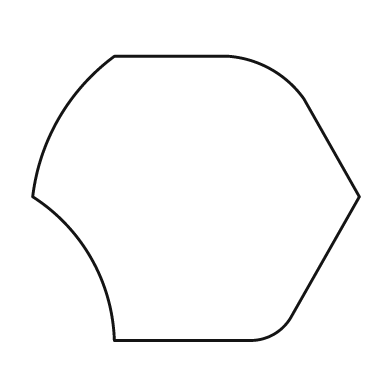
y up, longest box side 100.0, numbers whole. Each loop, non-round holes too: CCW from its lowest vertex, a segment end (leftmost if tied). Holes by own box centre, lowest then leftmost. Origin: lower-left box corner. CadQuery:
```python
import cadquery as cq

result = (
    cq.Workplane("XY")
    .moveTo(25.0, 0.0)
    .lineTo(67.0, 0.0)
    .threePointArc((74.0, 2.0), (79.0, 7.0))
    .lineTo(100.0, 44.0)
    .lineTo(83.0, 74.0)
    .threePointArc((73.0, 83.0), (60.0, 87.0))
    .lineTo(25.0, 87.0)
    .threePointArc((8.0, 68.0), (0.0, 44.0))
    .threePointArc((18.0, 25.0), (25.0, 0.0))
    .close()
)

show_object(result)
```